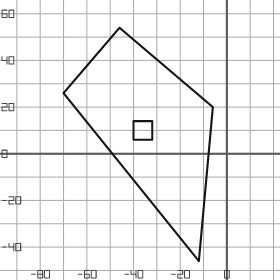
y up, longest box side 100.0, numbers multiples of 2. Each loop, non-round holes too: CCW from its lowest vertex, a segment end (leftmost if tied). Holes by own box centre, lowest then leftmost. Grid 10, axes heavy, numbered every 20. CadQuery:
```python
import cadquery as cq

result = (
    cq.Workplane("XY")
    .moveTo(-12.0, -46.0)
    .lineTo(-6.0, 20.0)
    .lineTo(-46.0, 54.0)
    .lineTo(-70.0, 26.0)
    .close()
    .moveTo(-40.0, 6.0)
    .lineTo(-32.0, 6.0)
    .lineTo(-32.0, 14.0)
    .lineTo(-40.0, 14.0)
    .close()
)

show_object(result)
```